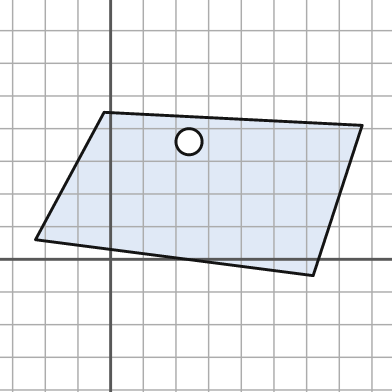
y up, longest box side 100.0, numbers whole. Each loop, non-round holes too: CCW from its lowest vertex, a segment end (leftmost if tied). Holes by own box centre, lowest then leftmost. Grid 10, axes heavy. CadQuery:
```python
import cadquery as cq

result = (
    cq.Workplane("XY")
    .moveTo(62.0, -5.0)
    .lineTo(77.0, 41.0)
    .lineTo(-2.0, 45.0)
    .lineTo(-23.0, 6.0)
    .close()
    .moveTo(24.0, 36.0)
    .circle(4.0)
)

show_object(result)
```